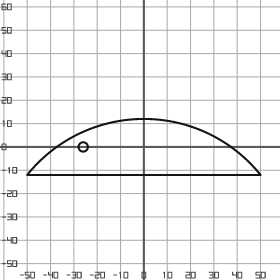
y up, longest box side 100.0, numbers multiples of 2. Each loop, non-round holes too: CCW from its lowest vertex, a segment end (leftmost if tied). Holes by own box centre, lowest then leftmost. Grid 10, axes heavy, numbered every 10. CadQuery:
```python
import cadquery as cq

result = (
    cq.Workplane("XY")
    .moveTo(-50.0, -12.0)
    .lineTo(50.0, -12.0)
    .threePointArc((0.0, 12.0), (-50.0, -12.0))
    .close()
    .moveTo(-26.0, 0.0)
    .circle(2.0)
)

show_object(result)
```